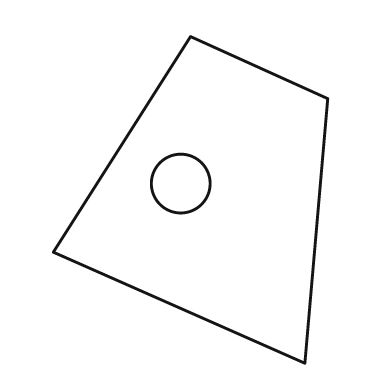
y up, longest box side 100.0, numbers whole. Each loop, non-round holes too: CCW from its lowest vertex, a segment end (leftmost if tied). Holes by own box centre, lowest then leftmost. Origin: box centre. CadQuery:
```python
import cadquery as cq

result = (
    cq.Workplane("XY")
    .moveTo(35.0, -50.0)
    .lineTo(42.0, 31.0)
    .lineTo(0.0, 50.0)
    .lineTo(-42.0, -16.0)
    .close()
    .moveTo(-3.0, 5.0)
    .circle(9.0)
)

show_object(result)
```